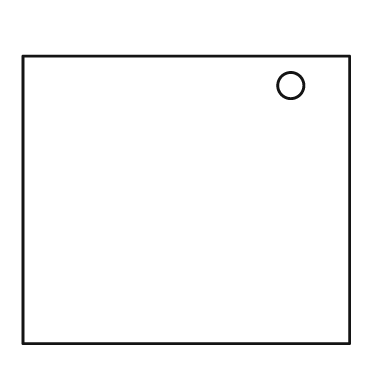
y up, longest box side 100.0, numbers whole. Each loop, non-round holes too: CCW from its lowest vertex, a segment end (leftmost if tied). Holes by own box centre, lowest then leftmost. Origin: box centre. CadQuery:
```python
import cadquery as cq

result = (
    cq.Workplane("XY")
    .moveTo(-50.0, -44.0)
    .lineTo(50.0, -44.0)
    .lineTo(50.0, 44.0)
    .lineTo(-50.0, 44.0)
    .close()
    .moveTo(32.0, 35.0)
    .circle(4.0)
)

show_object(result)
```